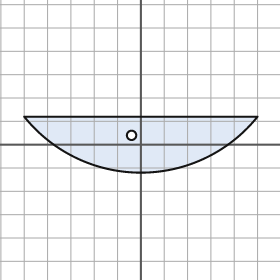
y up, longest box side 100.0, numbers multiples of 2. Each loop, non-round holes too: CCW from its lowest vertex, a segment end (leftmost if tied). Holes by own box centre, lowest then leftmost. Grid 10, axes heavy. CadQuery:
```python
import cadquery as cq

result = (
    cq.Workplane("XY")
    .moveTo(-50.0, 12.0)
    .threePointArc((0.0, -12.0), (50.0, 12.0))
    .close()
    .moveTo(-4.0, 4.0)
    .circle(2.0)
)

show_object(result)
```